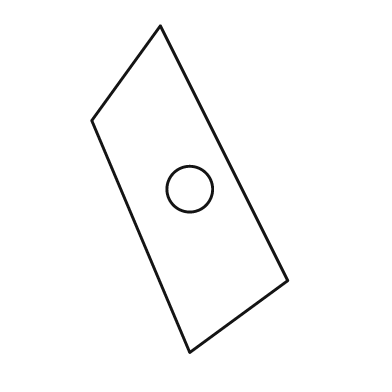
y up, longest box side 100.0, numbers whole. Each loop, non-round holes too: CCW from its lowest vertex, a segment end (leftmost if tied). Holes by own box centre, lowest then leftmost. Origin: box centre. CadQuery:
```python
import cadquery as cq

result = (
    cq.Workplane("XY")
    .moveTo(0.0, -50.0)
    .lineTo(30.0, -28.0)
    .lineTo(-9.0, 50.0)
    .lineTo(-30.0, 21.0)
    .close()
    .moveTo(0.0, 0.0)
    .circle(7.0)
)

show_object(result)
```